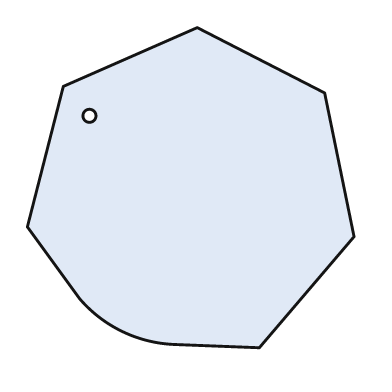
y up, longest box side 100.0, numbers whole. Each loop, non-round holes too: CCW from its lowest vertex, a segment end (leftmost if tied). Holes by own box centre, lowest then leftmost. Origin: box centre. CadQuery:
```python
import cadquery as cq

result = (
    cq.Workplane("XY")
    .moveTo(21.0, -49.0)
    .lineTo(50.0, -15.0)
    .lineTo(41.0, 29.0)
    .lineTo(2.0, 49.0)
    .lineTo(-39.0, 31.0)
    .lineTo(-50.0, -12.0)
    .lineTo(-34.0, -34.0)
    .threePointArc((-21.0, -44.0), (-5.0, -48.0))
    .close()
    .moveTo(-31.0, 22.0)
    .circle(2.0)
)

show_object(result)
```